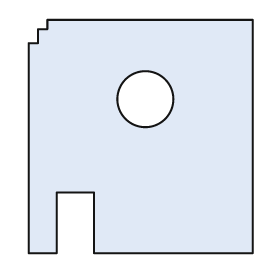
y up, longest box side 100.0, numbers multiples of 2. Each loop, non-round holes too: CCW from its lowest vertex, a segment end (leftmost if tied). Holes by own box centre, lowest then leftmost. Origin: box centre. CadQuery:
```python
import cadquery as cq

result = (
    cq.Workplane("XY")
    .moveTo(-48.0, -50.0)
    .lineTo(-36.0, -50.0)
    .lineTo(-36.0, -24.0)
    .lineTo(-20.0, -24.0)
    .lineTo(-20.0, -50.0)
    .lineTo(48.0, -50.0)
    .lineTo(48.0, 50.0)
    .lineTo(-40.0, 50.0)
    .lineTo(-40.0, 46.0)
    .lineTo(-44.0, 46.0)
    .lineTo(-44.0, 40.0)
    .lineTo(-48.0, 40.0)
    .close()
    .moveTo(2.0, 16.0)
    .circle(12.0)
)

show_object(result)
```